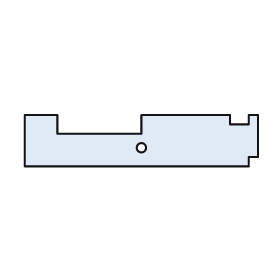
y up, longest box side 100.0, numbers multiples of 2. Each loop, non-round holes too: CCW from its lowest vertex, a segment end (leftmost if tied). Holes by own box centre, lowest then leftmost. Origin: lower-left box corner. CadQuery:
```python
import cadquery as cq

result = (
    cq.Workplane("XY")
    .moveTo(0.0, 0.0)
    .lineTo(96.0, 0.0)
    .lineTo(96.0, 4.0)
    .lineTo(100.0, 4.0)
    .lineTo(100.0, 22.0)
    .lineTo(96.0, 22.0)
    .lineTo(96.0, 18.0)
    .lineTo(88.0, 18.0)
    .lineTo(88.0, 22.0)
    .lineTo(50.0, 22.0)
    .lineTo(50.0, 14.0)
    .lineTo(14.0, 14.0)
    .lineTo(14.0, 22.0)
    .lineTo(0.0, 22.0)
    .close()
    .moveTo(50.0, 8.0)
    .circle(2.0)
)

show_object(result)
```